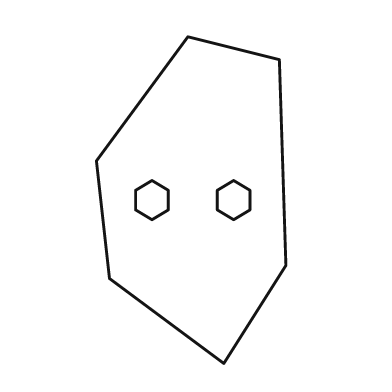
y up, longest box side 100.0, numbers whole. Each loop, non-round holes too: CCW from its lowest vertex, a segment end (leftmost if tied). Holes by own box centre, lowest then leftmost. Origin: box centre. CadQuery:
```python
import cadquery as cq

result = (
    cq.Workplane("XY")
    .moveTo(10.0, -50.0)
    .lineTo(29.0, -20.0)
    .lineTo(27.0, 43.0)
    .lineTo(-1.0, 50.0)
    .lineTo(-29.0, 12.0)
    .lineTo(-25.0, -24.0)
    .close()
    .moveTo(-12.0, -6.0)
    .lineTo(-7.0, -3.0)
    .lineTo(-7.0, 3.0)
    .lineTo(-12.0, 6.0)
    .lineTo(-17.0, 3.0)
    .lineTo(-17.0, -3.0)
    .close()
    .moveTo(13.0, -6.0)
    .lineTo(18.0, -3.0)
    .lineTo(18.0, 3.0)
    .lineTo(13.0, 6.0)
    .lineTo(8.0, 3.0)
    .lineTo(8.0, -3.0)
    .close()
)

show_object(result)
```